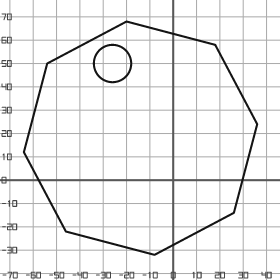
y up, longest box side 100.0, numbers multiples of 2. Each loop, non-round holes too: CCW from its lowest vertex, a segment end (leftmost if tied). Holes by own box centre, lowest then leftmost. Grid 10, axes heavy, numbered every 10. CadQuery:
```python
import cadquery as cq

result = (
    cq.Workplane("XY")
    .moveTo(-8.0, -32.0)
    .lineTo(26.0, -14.0)
    .lineTo(36.0, 24.0)
    .lineTo(18.0, 58.0)
    .lineTo(-20.0, 68.0)
    .lineTo(-54.0, 50.0)
    .lineTo(-64.0, 12.0)
    .lineTo(-46.0, -22.0)
    .close()
    .moveTo(-26.0, 50.0)
    .circle(8.0)
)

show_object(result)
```